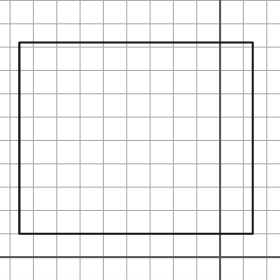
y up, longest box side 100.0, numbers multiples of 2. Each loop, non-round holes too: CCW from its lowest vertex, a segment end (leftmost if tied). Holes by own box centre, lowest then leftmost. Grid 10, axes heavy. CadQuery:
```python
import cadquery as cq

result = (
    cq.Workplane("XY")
    .moveTo(-86.0, 10.0)
    .lineTo(14.0, 10.0)
    .lineTo(14.0, 92.0)
    .lineTo(-86.0, 92.0)
    .close()
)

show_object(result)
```